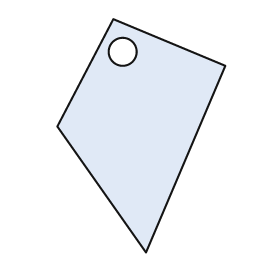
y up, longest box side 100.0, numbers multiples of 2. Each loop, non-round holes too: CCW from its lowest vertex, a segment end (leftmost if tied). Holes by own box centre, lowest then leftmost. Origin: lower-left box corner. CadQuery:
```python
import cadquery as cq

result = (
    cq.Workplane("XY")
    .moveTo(38.0, 0.0)
    .lineTo(72.0, 80.0)
    .lineTo(24.0, 100.0)
    .lineTo(0.0, 54.0)
    .close()
    .moveTo(28.0, 86.0)
    .circle(6.0)
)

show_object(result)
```